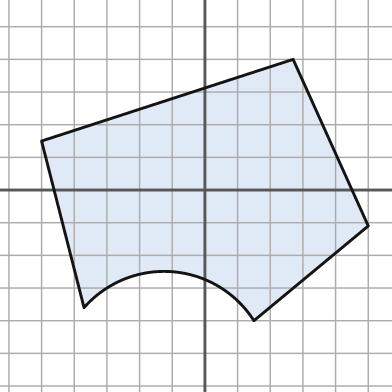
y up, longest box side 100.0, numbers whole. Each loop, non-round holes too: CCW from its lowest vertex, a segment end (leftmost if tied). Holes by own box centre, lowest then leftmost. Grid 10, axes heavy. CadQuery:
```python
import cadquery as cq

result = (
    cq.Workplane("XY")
    .moveTo(15.0, -40.0)
    .lineTo(50.0, -11.0)
    .lineTo(27.0, 40.0)
    .lineTo(-50.0, 15.0)
    .lineTo(-37.0, -36.0)
    .threePointArc((-10.0, -25.0), (15.0, -40.0))
    .close()
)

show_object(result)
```